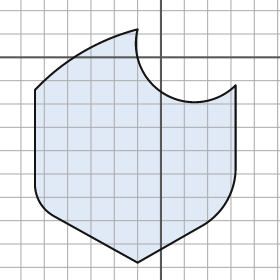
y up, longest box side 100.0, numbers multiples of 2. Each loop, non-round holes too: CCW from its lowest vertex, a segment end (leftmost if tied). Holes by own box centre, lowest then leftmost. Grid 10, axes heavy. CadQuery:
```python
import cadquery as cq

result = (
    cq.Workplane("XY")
    .moveTo(-10.0, -88.0)
    .lineTo(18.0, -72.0)
    .threePointArc((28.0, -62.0), (32.0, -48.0))
    .lineTo(32.0, -12.0)
    .threePointArc((2.0, -16.0), (-10.0, 12.0))
    .threePointArc((-34.0, 2.0), (-54.0, -14.0))
    .lineTo(-54.0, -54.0)
    .threePointArc((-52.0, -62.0), (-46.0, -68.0))
    .close()
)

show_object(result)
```